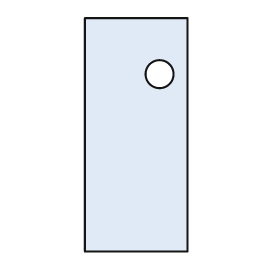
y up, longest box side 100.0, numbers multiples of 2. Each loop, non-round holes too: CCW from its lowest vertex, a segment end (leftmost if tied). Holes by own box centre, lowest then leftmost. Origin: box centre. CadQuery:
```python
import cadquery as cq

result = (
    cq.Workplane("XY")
    .moveTo(-22.0, -50.0)
    .lineTo(22.0, -50.0)
    .lineTo(22.0, 50.0)
    .lineTo(-22.0, 50.0)
    .close()
    .moveTo(10.0, 26.0)
    .circle(6.0)
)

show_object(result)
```